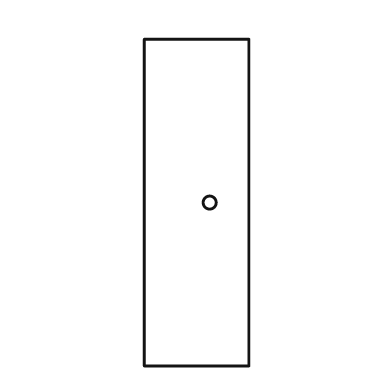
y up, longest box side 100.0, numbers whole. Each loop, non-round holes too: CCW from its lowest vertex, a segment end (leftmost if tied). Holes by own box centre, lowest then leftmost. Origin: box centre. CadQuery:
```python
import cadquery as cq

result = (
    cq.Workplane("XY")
    .moveTo(-16.0, -50.0)
    .lineTo(16.0, -50.0)
    .lineTo(16.0, 50.0)
    .lineTo(-16.0, 50.0)
    .close()
    .moveTo(4.0, 0.0)
    .circle(2.0)
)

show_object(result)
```